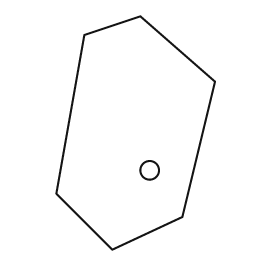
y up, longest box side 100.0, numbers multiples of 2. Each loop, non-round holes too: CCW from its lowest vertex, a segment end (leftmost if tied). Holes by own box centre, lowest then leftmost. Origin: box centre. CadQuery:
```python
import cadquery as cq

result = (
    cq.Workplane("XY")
    .moveTo(-10.0, -50.0)
    .lineTo(20.0, -36.0)
    .lineTo(34.0, 22.0)
    .lineTo(2.0, 50.0)
    .lineTo(-22.0, 42.0)
    .lineTo(-34.0, -26.0)
    .close()
    .moveTo(6.0, -16.0)
    .circle(4.0)
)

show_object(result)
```